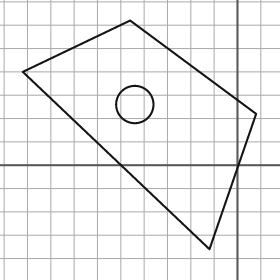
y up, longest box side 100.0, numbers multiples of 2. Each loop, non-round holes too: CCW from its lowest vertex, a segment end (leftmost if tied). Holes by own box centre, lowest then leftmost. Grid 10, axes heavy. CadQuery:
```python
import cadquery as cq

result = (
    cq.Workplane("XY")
    .moveTo(-12.0, -36.0)
    .lineTo(8.0, 22.0)
    .lineTo(-46.0, 62.0)
    .lineTo(-92.0, 40.0)
    .close()
    .moveTo(-44.0, 26.0)
    .circle(8.0)
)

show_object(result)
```